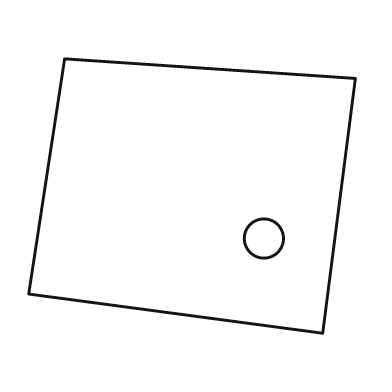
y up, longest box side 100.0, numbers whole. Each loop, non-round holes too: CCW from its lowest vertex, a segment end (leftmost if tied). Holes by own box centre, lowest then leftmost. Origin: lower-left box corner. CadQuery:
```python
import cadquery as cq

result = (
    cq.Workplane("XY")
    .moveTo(90.0, 0.0)
    .lineTo(100.0, 78.0)
    .lineTo(11.0, 84.0)
    .lineTo(0.0, 12.0)
    .close()
    .moveTo(72.0, 29.0)
    .circle(6.0)
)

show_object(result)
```